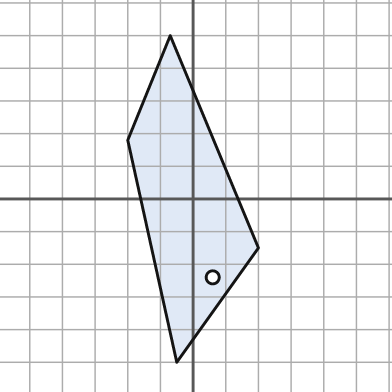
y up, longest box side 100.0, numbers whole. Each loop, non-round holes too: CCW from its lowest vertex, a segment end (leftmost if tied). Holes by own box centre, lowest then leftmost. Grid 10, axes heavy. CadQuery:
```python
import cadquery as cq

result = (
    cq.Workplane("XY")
    .moveTo(-5.0, -50.0)
    .lineTo(20.0, -15.0)
    .lineTo(-7.0, 50.0)
    .lineTo(-20.0, 18.0)
    .close()
    .moveTo(6.0, -24.0)
    .circle(2.0)
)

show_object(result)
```